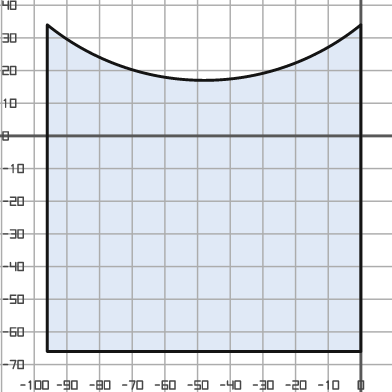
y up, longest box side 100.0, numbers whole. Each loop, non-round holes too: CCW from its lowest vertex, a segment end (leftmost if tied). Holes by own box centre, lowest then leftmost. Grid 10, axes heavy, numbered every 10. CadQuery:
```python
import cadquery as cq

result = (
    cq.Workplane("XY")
    .moveTo(-96.0, -66.0)
    .lineTo(0.0, -66.0)
    .lineTo(0.0, 34.0)
    .threePointArc((-48.0, 17.0), (-96.0, 34.0))
    .close()
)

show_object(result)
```